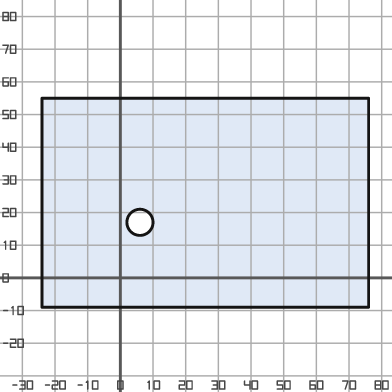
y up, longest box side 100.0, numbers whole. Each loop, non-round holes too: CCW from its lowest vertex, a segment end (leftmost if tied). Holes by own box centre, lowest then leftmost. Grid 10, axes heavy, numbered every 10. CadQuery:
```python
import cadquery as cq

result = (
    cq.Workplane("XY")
    .moveTo(-24.0, -9.0)
    .lineTo(76.0, -9.0)
    .lineTo(76.0, 55.0)
    .lineTo(-24.0, 55.0)
    .close()
    .moveTo(6.0, 17.0)
    .circle(4.0)
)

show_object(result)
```